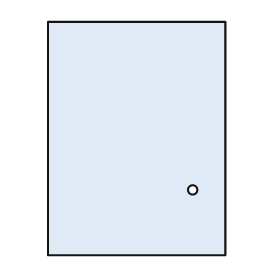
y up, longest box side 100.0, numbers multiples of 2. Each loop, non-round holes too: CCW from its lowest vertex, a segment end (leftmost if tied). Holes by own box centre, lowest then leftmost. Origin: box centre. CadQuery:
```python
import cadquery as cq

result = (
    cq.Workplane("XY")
    .moveTo(-38.0, -50.0)
    .lineTo(38.0, -50.0)
    .lineTo(38.0, 50.0)
    .lineTo(-38.0, 50.0)
    .close()
    .moveTo(24.0, -22.0)
    .circle(2.0)
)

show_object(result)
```